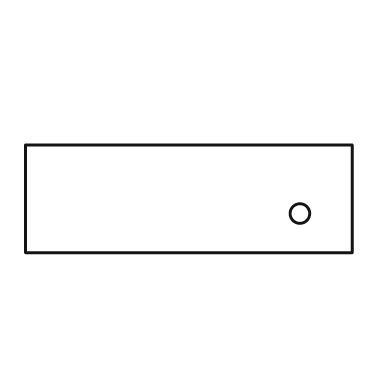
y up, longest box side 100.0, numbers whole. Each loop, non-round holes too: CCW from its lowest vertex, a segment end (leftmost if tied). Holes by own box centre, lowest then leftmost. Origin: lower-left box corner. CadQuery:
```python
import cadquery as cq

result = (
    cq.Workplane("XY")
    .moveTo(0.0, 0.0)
    .lineTo(100.0, 0.0)
    .lineTo(100.0, 33.0)
    .lineTo(0.0, 33.0)
    .close()
    .moveTo(84.0, 12.0)
    .circle(3.0)
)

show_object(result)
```